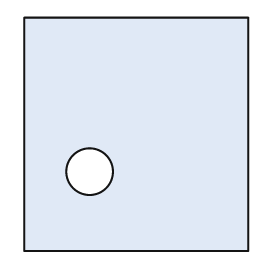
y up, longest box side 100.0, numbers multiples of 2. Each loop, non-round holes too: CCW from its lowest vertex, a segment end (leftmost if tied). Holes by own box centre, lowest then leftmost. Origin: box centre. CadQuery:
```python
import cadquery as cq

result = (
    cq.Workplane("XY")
    .moveTo(-48.0, -50.0)
    .lineTo(48.0, -50.0)
    .lineTo(48.0, 50.0)
    .lineTo(-48.0, 50.0)
    .close()
    .moveTo(-20.0, -16.0)
    .circle(10.0)
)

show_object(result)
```